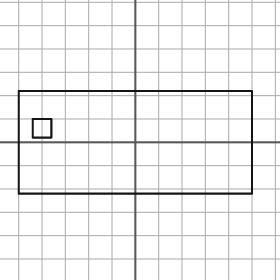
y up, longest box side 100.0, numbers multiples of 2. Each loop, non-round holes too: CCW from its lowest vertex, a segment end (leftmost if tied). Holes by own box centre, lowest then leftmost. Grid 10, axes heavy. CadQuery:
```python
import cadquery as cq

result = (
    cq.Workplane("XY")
    .moveTo(-50.0, -22.0)
    .lineTo(50.0, -22.0)
    .lineTo(50.0, 22.0)
    .lineTo(-50.0, 22.0)
    .close()
    .moveTo(-44.0, 2.0)
    .lineTo(-36.0, 2.0)
    .lineTo(-36.0, 10.0)
    .lineTo(-44.0, 10.0)
    .close()
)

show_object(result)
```